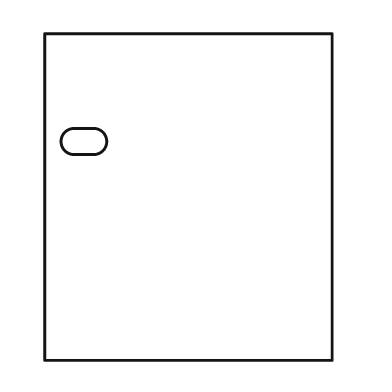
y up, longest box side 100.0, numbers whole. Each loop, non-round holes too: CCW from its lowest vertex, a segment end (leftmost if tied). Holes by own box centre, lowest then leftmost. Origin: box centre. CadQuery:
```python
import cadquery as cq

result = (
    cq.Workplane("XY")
    .moveTo(-44.0, -50.0)
    .lineTo(44.0, -50.0)
    .lineTo(44.0, 50.0)
    .lineTo(-44.0, 50.0)
    .close()
    .moveTo(-35.0, 13.0)
    .lineTo(-29.0, 13.0)
    .threePointArc((-25.0, 17.0), (-29.0, 21.0))
    .lineTo(-35.0, 21.0)
    .threePointArc((-39.0, 17.0), (-35.0, 13.0))
    .close()
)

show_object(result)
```